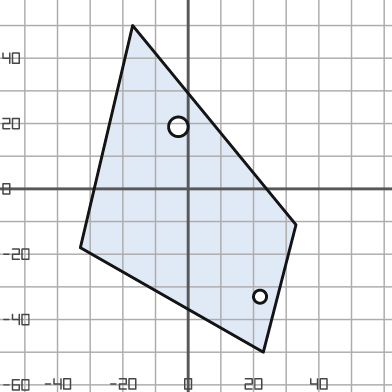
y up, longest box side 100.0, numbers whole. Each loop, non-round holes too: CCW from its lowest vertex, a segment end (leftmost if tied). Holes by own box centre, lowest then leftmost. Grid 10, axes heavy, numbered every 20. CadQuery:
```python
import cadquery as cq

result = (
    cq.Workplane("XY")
    .moveTo(23.0, -50.0)
    .lineTo(33.0, -11.0)
    .lineTo(-17.0, 50.0)
    .lineTo(-33.0, -18.0)
    .close()
    .moveTo(22.0, -33.0)
    .circle(2.0)
    .moveTo(-3.0, 19.0)
    .circle(3.0)
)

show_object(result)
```